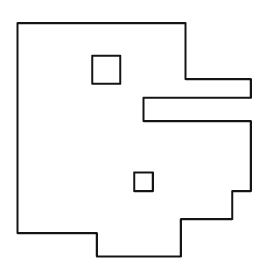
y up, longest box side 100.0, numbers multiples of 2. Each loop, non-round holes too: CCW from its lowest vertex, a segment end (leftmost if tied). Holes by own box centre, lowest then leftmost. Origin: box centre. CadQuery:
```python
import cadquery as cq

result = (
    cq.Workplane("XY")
    .moveTo(-16.0, -50.0)
    .lineTo(20.0, -50.0)
    .lineTo(20.0, -34.0)
    .lineTo(42.0, -34.0)
    .lineTo(42.0, -22.0)
    .lineTo(50.0, -22.0)
    .lineTo(50.0, 8.0)
    .lineTo(4.0, 8.0)
    .lineTo(4.0, 18.0)
    .lineTo(50.0, 18.0)
    .lineTo(50.0, 26.0)
    .lineTo(22.0, 26.0)
    .lineTo(22.0, 50.0)
    .lineTo(-50.0, 50.0)
    .lineTo(-50.0, -40.0)
    .lineTo(-16.0, -40.0)
    .close()
    .moveTo(0.0, -22.0)
    .lineTo(8.0, -22.0)
    .lineTo(8.0, -14.0)
    .lineTo(0.0, -14.0)
    .close()
    .moveTo(-18.0, 24.0)
    .lineTo(-6.0, 24.0)
    .lineTo(-6.0, 36.0)
    .lineTo(-18.0, 36.0)
    .close()
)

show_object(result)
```